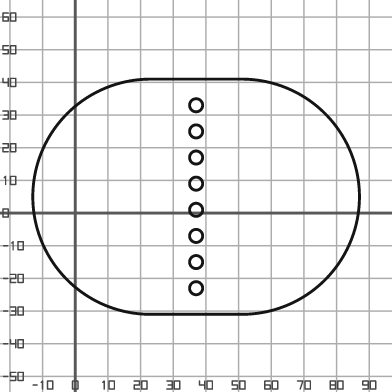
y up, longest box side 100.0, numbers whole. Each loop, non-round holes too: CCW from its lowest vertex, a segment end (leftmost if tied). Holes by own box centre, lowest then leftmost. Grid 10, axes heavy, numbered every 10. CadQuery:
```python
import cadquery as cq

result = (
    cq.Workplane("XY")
    .moveTo(23.0, -31.0)
    .lineTo(51.0, -31.0)
    .threePointArc((87.0, 5.0), (51.0, 41.0))
    .lineTo(23.0, 41.0)
    .threePointArc((-13.0, 5.0), (23.0, -31.0))
    .close()
    .moveTo(37.0, -23.0)
    .circle(2.0)
    .moveTo(37.0, -15.0)
    .circle(2.0)
    .moveTo(37.0, -7.0)
    .circle(2.0)
    .moveTo(37.0, 1.0)
    .circle(2.0)
    .moveTo(37.0, 9.0)
    .circle(2.0)
    .moveTo(37.0, 17.0)
    .circle(2.0)
    .moveTo(37.0, 25.0)
    .circle(2.0)
    .moveTo(37.0, 33.0)
    .circle(2.0)
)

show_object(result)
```